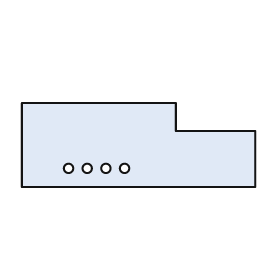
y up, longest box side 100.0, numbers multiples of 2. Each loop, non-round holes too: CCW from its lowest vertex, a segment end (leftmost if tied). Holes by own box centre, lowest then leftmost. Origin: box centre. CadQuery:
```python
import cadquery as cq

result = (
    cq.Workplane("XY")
    .moveTo(-50.0, -18.0)
    .lineTo(50.0, -18.0)
    .lineTo(50.0, 6.0)
    .lineTo(16.0, 6.0)
    .lineTo(16.0, 18.0)
    .lineTo(-50.0, 18.0)
    .close()
    .moveTo(-30.0, -10.0)
    .circle(2.0)
    .moveTo(-22.0, -10.0)
    .circle(2.0)
    .moveTo(-14.0, -10.0)
    .circle(2.0)
    .moveTo(-6.0, -10.0)
    .circle(2.0)
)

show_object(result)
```